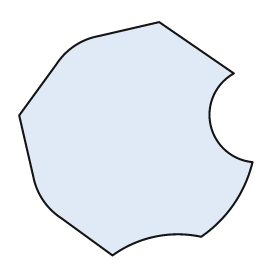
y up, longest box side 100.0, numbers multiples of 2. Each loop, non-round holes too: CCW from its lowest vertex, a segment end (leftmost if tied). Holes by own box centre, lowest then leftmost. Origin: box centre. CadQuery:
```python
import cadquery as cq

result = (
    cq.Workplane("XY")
    .moveTo(-10.0, -50.0)
    .threePointArc((8.0, -42.0), (28.0, -42.0))
    .threePointArc((42.0, -28.0), (50.0, -10.0))
    .threePointArc((32.0, 6.0), (42.0, 28.0))
    .lineTo(10.0, 50.0)
    .lineTo(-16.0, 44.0)
    .threePointArc((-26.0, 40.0), (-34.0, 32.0))
    .lineTo(-50.0, 10.0)
    .lineTo(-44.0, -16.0)
    .threePointArc((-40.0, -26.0), (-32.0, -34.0))
    .close()
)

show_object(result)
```